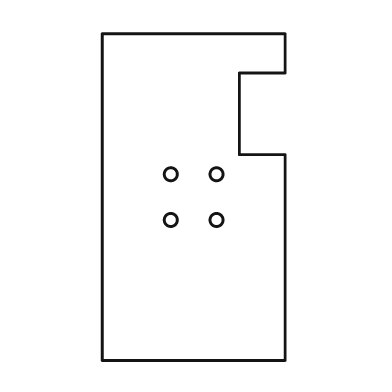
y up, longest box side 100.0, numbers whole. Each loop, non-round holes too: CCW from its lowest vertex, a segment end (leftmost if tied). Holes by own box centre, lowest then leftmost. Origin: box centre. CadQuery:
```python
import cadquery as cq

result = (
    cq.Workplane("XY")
    .moveTo(-28.0, -50.0)
    .lineTo(28.0, -50.0)
    .lineTo(28.0, 13.0)
    .lineTo(14.0, 13.0)
    .lineTo(14.0, 38.0)
    .lineTo(28.0, 38.0)
    .lineTo(28.0, 50.0)
    .lineTo(-28.0, 50.0)
    .close()
    .moveTo(-7.0, -7.0)
    .circle(2.0)
    .moveTo(7.0, -7.0)
    .circle(2.0)
    .moveTo(-7.0, 7.0)
    .circle(2.0)
    .moveTo(7.0, 7.0)
    .circle(2.0)
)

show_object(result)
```